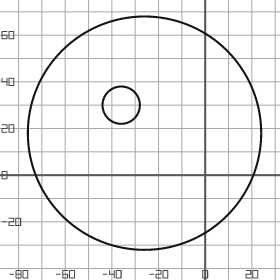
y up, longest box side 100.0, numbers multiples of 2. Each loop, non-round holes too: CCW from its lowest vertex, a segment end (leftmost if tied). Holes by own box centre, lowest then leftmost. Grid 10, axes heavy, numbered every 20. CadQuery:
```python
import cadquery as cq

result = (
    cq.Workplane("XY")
    .moveTo(-26.0, 18.0)
    .circle(50.0)
    .moveTo(-36.0, 30.0)
    .circle(8.0)
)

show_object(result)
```